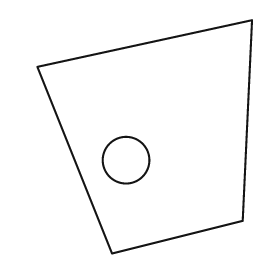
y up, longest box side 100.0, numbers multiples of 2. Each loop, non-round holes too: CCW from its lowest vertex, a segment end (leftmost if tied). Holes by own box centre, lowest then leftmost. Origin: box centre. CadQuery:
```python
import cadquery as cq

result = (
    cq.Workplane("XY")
    .moveTo(-14.0, -50.0)
    .lineTo(42.0, -36.0)
    .lineTo(46.0, 50.0)
    .lineTo(-46.0, 30.0)
    .close()
    .moveTo(-8.0, -10.0)
    .circle(10.0)
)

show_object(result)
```